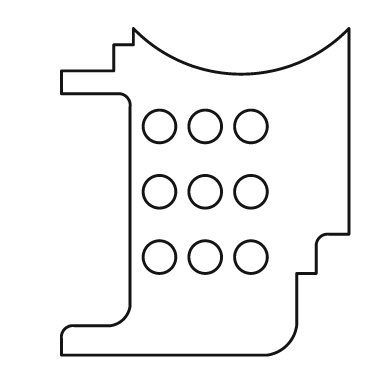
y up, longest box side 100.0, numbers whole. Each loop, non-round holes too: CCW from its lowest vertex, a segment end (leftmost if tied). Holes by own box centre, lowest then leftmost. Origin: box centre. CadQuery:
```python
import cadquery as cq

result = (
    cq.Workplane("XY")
    .moveTo(-44.0, -50.0)
    .lineTo(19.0, -50.0)
    .threePointArc((25.0, -47.0), (28.0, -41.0))
    .lineTo(28.0, -25.0)
    .lineTo(34.0, -25.0)
    .lineTo(34.0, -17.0)
    .threePointArc((35.0, -14.0), (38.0, -13.0))
    .lineTo(44.0, -13.0)
    .lineTo(44.0, 50.0)
    .threePointArc((11.0, 36.0), (-22.0, 50.0))
    .lineTo(-22.0, 45.0)
    .lineTo(-28.0, 45.0)
    .lineTo(-28.0, 37.0)
    .lineTo(-44.0, 37.0)
    .lineTo(-44.0, 30.0)
    .lineTo(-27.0, 30.0)
    .threePointArc((-24.0, 29.0), (-23.0, 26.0))
    .lineTo(-23.0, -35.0)
    .threePointArc((-25.0, -39.0), (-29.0, -41.0))
    .lineTo(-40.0, -41.0)
    .threePointArc((-43.0, -42.0), (-44.0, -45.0))
    .close()
    .moveTo(-14.0, -20.0)
    .circle(5.0)
    .moveTo(0.0, -20.0)
    .circle(5.0)
    .moveTo(14.0, -20.0)
    .circle(5.0)
    .moveTo(-14.0, 0.0)
    .circle(5.0)
    .moveTo(0.0, 0.0)
    .circle(5.0)
    .moveTo(14.0, 0.0)
    .circle(5.0)
    .moveTo(-14.0, 20.0)
    .circle(5.0)
    .moveTo(0.0, 20.0)
    .circle(5.0)
    .moveTo(14.0, 20.0)
    .circle(5.0)
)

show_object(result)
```